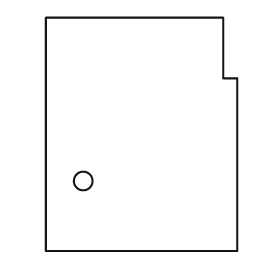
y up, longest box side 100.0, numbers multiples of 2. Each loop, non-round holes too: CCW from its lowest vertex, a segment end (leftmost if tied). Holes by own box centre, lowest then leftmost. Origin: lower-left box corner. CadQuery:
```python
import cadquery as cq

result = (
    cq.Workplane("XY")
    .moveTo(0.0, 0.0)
    .lineTo(82.0, 0.0)
    .lineTo(82.0, 74.0)
    .lineTo(76.0, 74.0)
    .lineTo(76.0, 100.0)
    .lineTo(0.0, 100.0)
    .close()
    .moveTo(16.0, 30.0)
    .circle(4.0)
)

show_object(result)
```